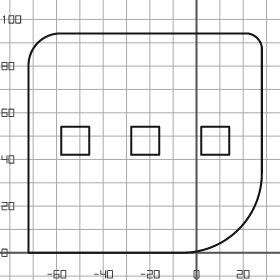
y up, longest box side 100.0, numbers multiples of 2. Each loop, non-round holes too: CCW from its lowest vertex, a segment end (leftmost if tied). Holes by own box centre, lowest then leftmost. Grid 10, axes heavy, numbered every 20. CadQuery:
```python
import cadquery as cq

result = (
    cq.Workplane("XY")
    .moveTo(-72.0, 0.0)
    .lineTo(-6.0, 0.0)
    .threePointArc((18.0, 10.0), (28.0, 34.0))
    .lineTo(28.0, 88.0)
    .threePointArc((26.0, 92.0), (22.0, 94.0))
    .lineTo(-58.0, 94.0)
    .threePointArc((-68.0, 90.0), (-72.0, 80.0))
    .close()
    .moveTo(-58.0, 42.0)
    .lineTo(-46.0, 42.0)
    .lineTo(-46.0, 54.0)
    .lineTo(-58.0, 54.0)
    .close()
    .moveTo(-28.0, 42.0)
    .lineTo(-16.0, 42.0)
    .lineTo(-16.0, 54.0)
    .lineTo(-28.0, 54.0)
    .close()
    .moveTo(2.0, 42.0)
    .lineTo(14.0, 42.0)
    .lineTo(14.0, 54.0)
    .lineTo(2.0, 54.0)
    .close()
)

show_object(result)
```